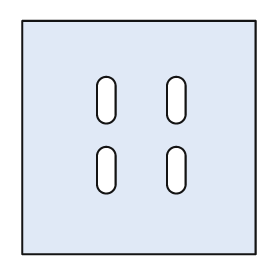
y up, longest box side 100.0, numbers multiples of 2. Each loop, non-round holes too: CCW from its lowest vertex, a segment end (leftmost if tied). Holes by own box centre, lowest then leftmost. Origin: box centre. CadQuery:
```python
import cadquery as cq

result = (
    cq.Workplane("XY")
    .moveTo(-50.0, -50.0)
    .lineTo(50.0, -50.0)
    .lineTo(50.0, 50.0)
    .lineTo(-50.0, 50.0)
    .close()
    .moveTo(-18.0, -20.0)
    .threePointArc((-14.0, -24.0), (-10.0, -20.0))
    .lineTo(-10.0, -8.0)
    .threePointArc((-14.0, -4.0), (-18.0, -8.0))
    .close()
    .moveTo(12.0, -20.0)
    .threePointArc((16.0, -24.0), (20.0, -20.0))
    .lineTo(20.0, -8.0)
    .threePointArc((16.0, -4.0), (12.0, -8.0))
    .close()
    .moveTo(-18.0, 10.0)
    .threePointArc((-14.0, 6.0), (-10.0, 10.0))
    .lineTo(-10.0, 22.0)
    .threePointArc((-14.0, 26.0), (-18.0, 22.0))
    .close()
    .moveTo(12.0, 10.0)
    .threePointArc((16.0, 6.0), (20.0, 10.0))
    .lineTo(20.0, 22.0)
    .threePointArc((16.0, 26.0), (12.0, 22.0))
    .close()
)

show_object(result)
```